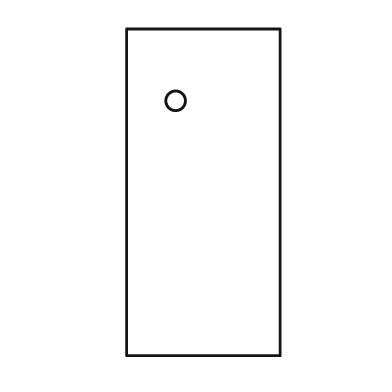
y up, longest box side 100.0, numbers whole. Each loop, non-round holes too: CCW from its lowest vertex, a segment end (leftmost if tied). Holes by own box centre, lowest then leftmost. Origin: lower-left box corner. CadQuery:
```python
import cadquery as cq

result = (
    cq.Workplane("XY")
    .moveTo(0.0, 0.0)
    .lineTo(47.0, 0.0)
    .lineTo(47.0, 100.0)
    .lineTo(0.0, 100.0)
    .close()
    .moveTo(15.0, 78.0)
    .circle(3.0)
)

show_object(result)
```